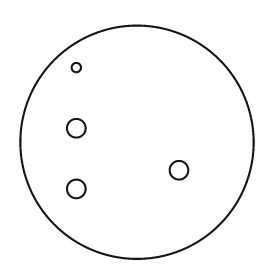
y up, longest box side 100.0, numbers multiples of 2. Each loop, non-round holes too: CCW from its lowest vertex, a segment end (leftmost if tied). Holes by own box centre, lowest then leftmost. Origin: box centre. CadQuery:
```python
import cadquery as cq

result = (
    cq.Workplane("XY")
    .moveTo(0.0, 0.0)
    .circle(50.0)
    .moveTo(-26.0, -20.0)
    .circle(4.0)
    .moveTo(18.0, -12.0)
    .circle(4.0)
    .moveTo(-26.0, 6.0)
    .circle(4.0)
    .moveTo(-26.0, 32.0)
    .circle(2.0)
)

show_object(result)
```